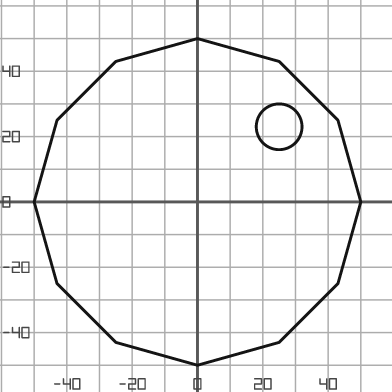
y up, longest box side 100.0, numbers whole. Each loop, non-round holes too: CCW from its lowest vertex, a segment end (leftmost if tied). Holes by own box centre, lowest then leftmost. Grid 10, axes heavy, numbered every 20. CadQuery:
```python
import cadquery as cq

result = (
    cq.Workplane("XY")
    .moveTo(0.0, -50.0)
    .lineTo(25.0, -43.0)
    .lineTo(43.0, -25.0)
    .lineTo(50.0, 0.0)
    .lineTo(43.0, 25.0)
    .lineTo(25.0, 43.0)
    .lineTo(0.0, 50.0)
    .lineTo(-25.0, 43.0)
    .lineTo(-43.0, 25.0)
    .lineTo(-50.0, 0.0)
    .lineTo(-43.0, -25.0)
    .lineTo(-25.0, -43.0)
    .close()
    .moveTo(25.0, 23.0)
    .circle(7.0)
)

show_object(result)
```